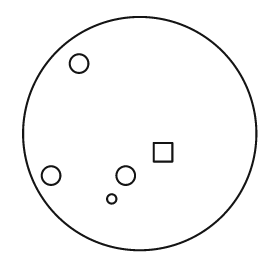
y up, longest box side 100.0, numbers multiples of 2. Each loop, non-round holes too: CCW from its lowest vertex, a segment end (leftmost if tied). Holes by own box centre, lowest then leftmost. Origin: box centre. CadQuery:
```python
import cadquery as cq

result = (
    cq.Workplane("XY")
    .moveTo(0.0, 0.0)
    .circle(50.0)
    .moveTo(-12.0, -28.0)
    .circle(2.0)
    .moveTo(-38.0, -18.0)
    .circle(4.0)
    .moveTo(-6.0, -18.0)
    .circle(4.0)
    .moveTo(6.0, -12.0)
    .lineTo(14.0, -12.0)
    .lineTo(14.0, -4.0)
    .lineTo(6.0, -4.0)
    .close()
    .moveTo(-26.0, 30.0)
    .circle(4.0)
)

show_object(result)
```